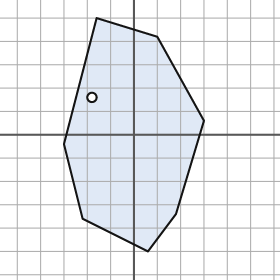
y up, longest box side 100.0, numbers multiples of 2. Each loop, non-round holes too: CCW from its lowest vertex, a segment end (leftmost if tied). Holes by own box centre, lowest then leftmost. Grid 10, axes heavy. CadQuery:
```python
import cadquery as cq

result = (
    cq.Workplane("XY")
    .moveTo(6.0, -50.0)
    .lineTo(18.0, -34.0)
    .lineTo(30.0, 6.0)
    .lineTo(10.0, 42.0)
    .lineTo(-16.0, 50.0)
    .lineTo(-30.0, -4.0)
    .lineTo(-22.0, -36.0)
    .close()
    .moveTo(-18.0, 16.0)
    .circle(2.0)
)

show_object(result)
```